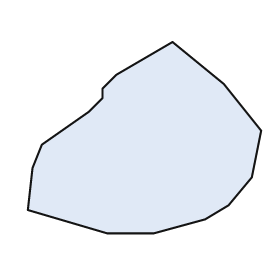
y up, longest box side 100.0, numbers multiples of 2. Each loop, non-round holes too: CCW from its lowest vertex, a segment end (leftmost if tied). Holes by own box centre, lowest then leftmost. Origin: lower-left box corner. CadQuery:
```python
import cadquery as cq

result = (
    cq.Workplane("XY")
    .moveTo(34.0, 0.0)
    .lineTo(54.0, 0.0)
    .lineTo(76.0, 6.0)
    .lineTo(86.0, 12.0)
    .lineTo(96.0, 24.0)
    .lineTo(100.0, 44.0)
    .lineTo(84.0, 64.0)
    .lineTo(62.0, 82.0)
    .lineTo(38.0, 68.0)
    .lineTo(32.0, 62.0)
    .lineTo(32.0, 58.0)
    .lineTo(26.0, 52.0)
    .lineTo(6.0, 38.0)
    .lineTo(2.0, 28.0)
    .lineTo(0.0, 10.0)
    .close()
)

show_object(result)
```